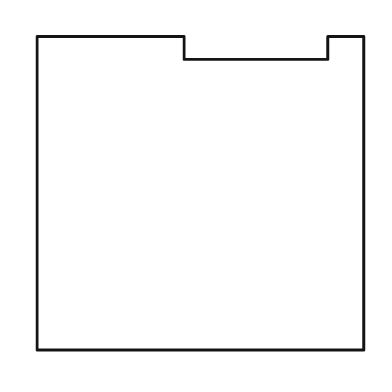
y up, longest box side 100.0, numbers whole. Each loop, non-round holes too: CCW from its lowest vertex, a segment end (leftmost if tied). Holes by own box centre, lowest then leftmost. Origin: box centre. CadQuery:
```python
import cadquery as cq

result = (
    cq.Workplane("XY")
    .moveTo(-50.0, -48.0)
    .lineTo(50.0, -48.0)
    .lineTo(50.0, 48.0)
    .lineTo(39.0, 48.0)
    .lineTo(39.0, 41.0)
    .lineTo(-5.0, 41.0)
    .lineTo(-5.0, 48.0)
    .lineTo(-50.0, 48.0)
    .close()
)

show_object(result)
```